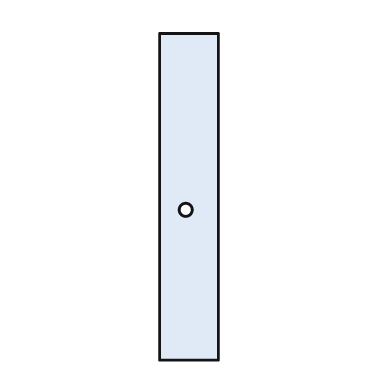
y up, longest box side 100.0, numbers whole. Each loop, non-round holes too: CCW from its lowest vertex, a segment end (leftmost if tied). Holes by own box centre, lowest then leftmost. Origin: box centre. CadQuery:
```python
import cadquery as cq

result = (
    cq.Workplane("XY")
    .moveTo(-9.0, -50.0)
    .lineTo(9.0, -50.0)
    .lineTo(9.0, 50.0)
    .lineTo(-9.0, 50.0)
    .close()
    .moveTo(-1.0, -4.0)
    .circle(2.0)
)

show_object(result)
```